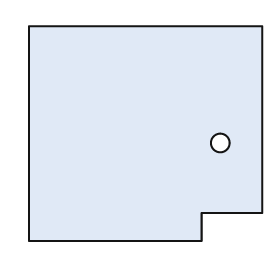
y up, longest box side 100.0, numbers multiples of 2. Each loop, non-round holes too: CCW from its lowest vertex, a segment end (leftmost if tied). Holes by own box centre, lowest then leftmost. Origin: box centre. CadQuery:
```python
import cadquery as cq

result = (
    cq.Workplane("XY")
    .moveTo(-50.0, -46.0)
    .lineTo(24.0, -46.0)
    .lineTo(24.0, -34.0)
    .lineTo(50.0, -34.0)
    .lineTo(50.0, 46.0)
    .lineTo(-50.0, 46.0)
    .close()
    .moveTo(32.0, -4.0)
    .circle(4.0)
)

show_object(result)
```